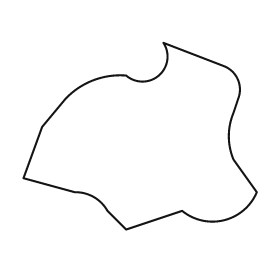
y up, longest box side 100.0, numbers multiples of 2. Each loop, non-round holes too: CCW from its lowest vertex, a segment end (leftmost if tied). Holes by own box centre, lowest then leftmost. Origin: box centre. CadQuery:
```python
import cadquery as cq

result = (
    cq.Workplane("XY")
    .moveTo(-6.0, -40.0)
    .lineTo(18.0, -32.0)
    .threePointArc((36.0, -36.0), (50.0, -24.0))
    .lineTo(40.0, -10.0)
    .threePointArc((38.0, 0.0), (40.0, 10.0))
    .lineTo(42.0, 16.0)
    .threePointArc((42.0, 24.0), (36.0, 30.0))
    .lineTo(10.0, 40.0)
    .threePointArc((8.0, 26.0), (-6.0, 26.0))
    .threePointArc((-20.0, 24.0), (-32.0, 16.0))
    .lineTo(-42.0, 4.0)
    .lineTo(-50.0, -18.0)
    .lineTo(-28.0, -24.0)
    .threePointArc((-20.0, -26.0), (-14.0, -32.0))
    .close()
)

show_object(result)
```